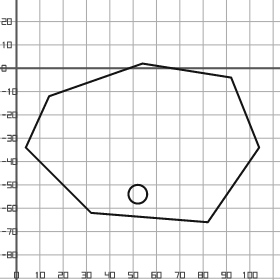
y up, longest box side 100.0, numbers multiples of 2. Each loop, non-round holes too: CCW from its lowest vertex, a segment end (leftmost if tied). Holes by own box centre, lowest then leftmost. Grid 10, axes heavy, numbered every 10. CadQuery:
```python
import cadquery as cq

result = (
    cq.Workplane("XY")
    .moveTo(82.0, -66.0)
    .lineTo(104.0, -34.0)
    .lineTo(92.0, -4.0)
    .lineTo(54.0, 2.0)
    .lineTo(14.0, -12.0)
    .lineTo(4.0, -34.0)
    .lineTo(32.0, -62.0)
    .close()
    .moveTo(52.0, -54.0)
    .circle(4.0)
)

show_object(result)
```